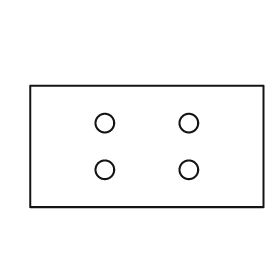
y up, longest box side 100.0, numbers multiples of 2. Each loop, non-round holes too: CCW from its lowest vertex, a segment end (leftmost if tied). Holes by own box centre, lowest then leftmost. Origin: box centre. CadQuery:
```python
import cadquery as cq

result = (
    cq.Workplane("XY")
    .moveTo(-50.0, -26.0)
    .lineTo(50.0, -26.0)
    .lineTo(50.0, 26.0)
    .lineTo(-50.0, 26.0)
    .close()
    .moveTo(-18.0, -10.0)
    .circle(4.0)
    .moveTo(18.0, -10.0)
    .circle(4.0)
    .moveTo(-18.0, 10.0)
    .circle(4.0)
    .moveTo(18.0, 10.0)
    .circle(4.0)
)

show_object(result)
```